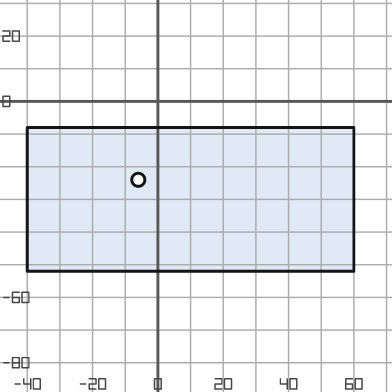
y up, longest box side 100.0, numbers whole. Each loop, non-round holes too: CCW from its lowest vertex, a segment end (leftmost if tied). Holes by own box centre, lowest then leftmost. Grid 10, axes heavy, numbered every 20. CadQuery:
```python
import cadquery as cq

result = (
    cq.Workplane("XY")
    .moveTo(-40.0, -52.0)
    .lineTo(60.0, -52.0)
    .lineTo(60.0, -8.0)
    .lineTo(-40.0, -8.0)
    .close()
    .moveTo(-6.0, -24.0)
    .circle(2.0)
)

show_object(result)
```